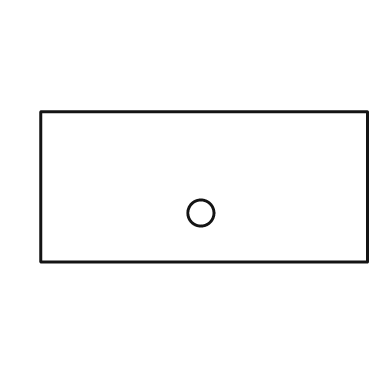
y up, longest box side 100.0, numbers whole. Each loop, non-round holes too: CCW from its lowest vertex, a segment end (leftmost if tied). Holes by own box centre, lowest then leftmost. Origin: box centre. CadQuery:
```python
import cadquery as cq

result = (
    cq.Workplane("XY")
    .moveTo(-50.0, -23.0)
    .lineTo(50.0, -23.0)
    .lineTo(50.0, 23.0)
    .lineTo(-50.0, 23.0)
    .close()
    .moveTo(-1.0, -8.0)
    .circle(4.0)
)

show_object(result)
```